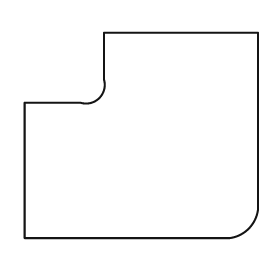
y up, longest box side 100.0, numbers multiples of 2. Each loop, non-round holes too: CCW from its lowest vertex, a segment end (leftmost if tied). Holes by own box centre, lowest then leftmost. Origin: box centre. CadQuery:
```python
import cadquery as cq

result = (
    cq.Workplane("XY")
    .moveTo(-50.0, -44.0)
    .lineTo(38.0, -44.0)
    .threePointArc((46.0, -40.0), (50.0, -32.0))
    .lineTo(50.0, 44.0)
    .lineTo(-16.0, 44.0)
    .lineTo(-16.0, 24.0)
    .threePointArc((-18.0, 16.0), (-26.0, 14.0))
    .lineTo(-50.0, 14.0)
    .close()
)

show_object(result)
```